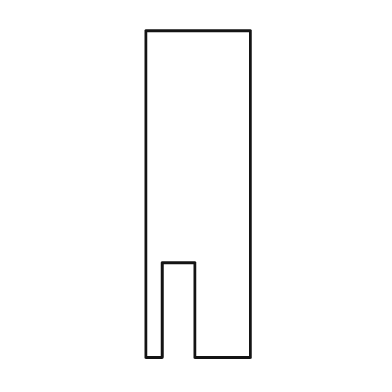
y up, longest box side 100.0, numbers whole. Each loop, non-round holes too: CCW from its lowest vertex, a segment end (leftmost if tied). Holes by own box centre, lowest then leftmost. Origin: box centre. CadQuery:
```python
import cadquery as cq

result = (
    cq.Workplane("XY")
    .moveTo(-16.0, -50.0)
    .lineTo(-11.0, -50.0)
    .lineTo(-11.0, -21.0)
    .lineTo(-1.0, -21.0)
    .lineTo(-1.0, -50.0)
    .lineTo(16.0, -50.0)
    .lineTo(16.0, 50.0)
    .lineTo(-16.0, 50.0)
    .close()
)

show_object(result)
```